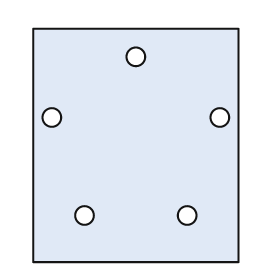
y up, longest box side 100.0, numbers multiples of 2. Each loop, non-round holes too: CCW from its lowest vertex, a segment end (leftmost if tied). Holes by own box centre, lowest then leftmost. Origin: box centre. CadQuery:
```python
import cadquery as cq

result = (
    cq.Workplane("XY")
    .moveTo(-44.0, -50.0)
    .lineTo(44.0, -50.0)
    .lineTo(44.0, 50.0)
    .lineTo(-44.0, 50.0)
    .close()
    .moveTo(-22.0, -30.0)
    .circle(4.0)
    .moveTo(22.0, -30.0)
    .circle(4.0)
    .moveTo(-36.0, 12.0)
    .circle(4.0)
    .moveTo(36.0, 12.0)
    .circle(4.0)
    .moveTo(0.0, 38.0)
    .circle(4.0)
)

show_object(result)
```